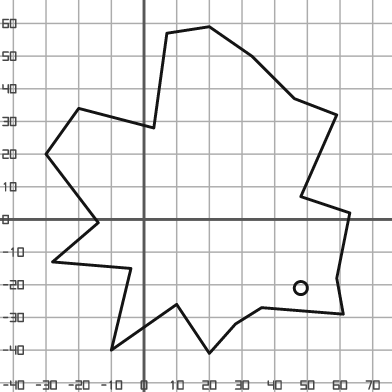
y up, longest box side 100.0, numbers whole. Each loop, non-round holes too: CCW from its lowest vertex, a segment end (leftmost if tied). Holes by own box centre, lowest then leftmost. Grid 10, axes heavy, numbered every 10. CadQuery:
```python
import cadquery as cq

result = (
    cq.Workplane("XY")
    .moveTo(20.0, -41.0)
    .lineTo(28.0, -32.0)
    .lineTo(36.0, -27.0)
    .lineTo(61.0, -29.0)
    .lineTo(59.0, -18.0)
    .lineTo(63.0, 2.0)
    .lineTo(48.0, 7.0)
    .lineTo(59.0, 32.0)
    .lineTo(46.0, 37.0)
    .lineTo(33.0, 50.0)
    .lineTo(20.0, 59.0)
    .lineTo(7.0, 57.0)
    .lineTo(3.0, 28.0)
    .lineTo(-20.0, 34.0)
    .lineTo(-30.0, 20.0)
    .lineTo(-14.0, -1.0)
    .lineTo(-28.0, -13.0)
    .lineTo(-4.0, -15.0)
    .lineTo(-10.0, -40.0)
    .lineTo(10.0, -26.0)
    .close()
    .moveTo(48.0, -21.0)
    .circle(2.0)
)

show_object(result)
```